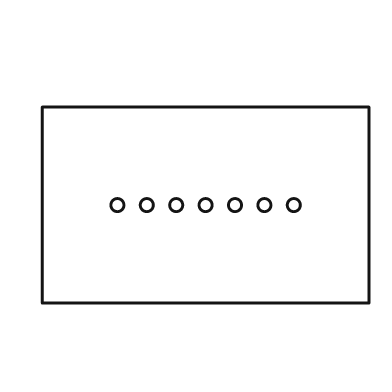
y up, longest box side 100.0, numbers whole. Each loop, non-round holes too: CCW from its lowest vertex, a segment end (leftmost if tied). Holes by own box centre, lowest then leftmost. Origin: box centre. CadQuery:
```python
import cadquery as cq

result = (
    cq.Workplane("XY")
    .moveTo(-50.0, -30.0)
    .lineTo(50.0, -30.0)
    .lineTo(50.0, 30.0)
    .lineTo(-50.0, 30.0)
    .close()
    .moveTo(-27.0, 0.0)
    .circle(2.0)
    .moveTo(-18.0, 0.0)
    .circle(2.0)
    .moveTo(-9.0, 0.0)
    .circle(2.0)
    .moveTo(0.0, 0.0)
    .circle(2.0)
    .moveTo(9.0, 0.0)
    .circle(2.0)
    .moveTo(18.0, 0.0)
    .circle(2.0)
    .moveTo(27.0, 0.0)
    .circle(2.0)
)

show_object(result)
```